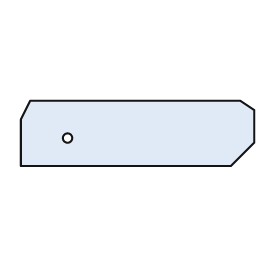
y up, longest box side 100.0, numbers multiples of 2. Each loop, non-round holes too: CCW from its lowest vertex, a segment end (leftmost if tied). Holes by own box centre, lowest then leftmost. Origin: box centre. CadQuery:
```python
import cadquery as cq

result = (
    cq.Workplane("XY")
    .moveTo(-50.0, -14.0)
    .lineTo(40.0, -14.0)
    .lineTo(50.0, -4.0)
    .lineTo(50.0, 10.0)
    .lineTo(44.0, 14.0)
    .lineTo(-46.0, 14.0)
    .lineTo(-50.0, 6.0)
    .close()
    .moveTo(-30.0, -2.0)
    .circle(2.0)
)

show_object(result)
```